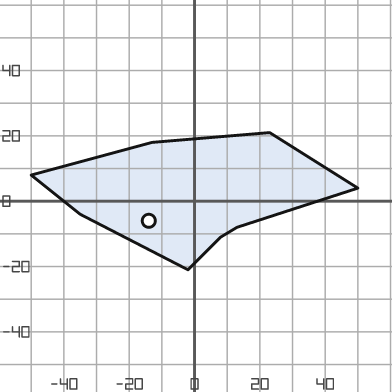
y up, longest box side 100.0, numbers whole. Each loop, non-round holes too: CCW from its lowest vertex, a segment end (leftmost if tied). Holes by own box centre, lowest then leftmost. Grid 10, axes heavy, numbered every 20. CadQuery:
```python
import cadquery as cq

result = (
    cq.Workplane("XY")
    .moveTo(-2.0, -21.0)
    .lineTo(8.0, -11.0)
    .lineTo(13.0, -8.0)
    .lineTo(50.0, 4.0)
    .lineTo(23.0, 21.0)
    .lineTo(-13.0, 18.0)
    .lineTo(-50.0, 8.0)
    .lineTo(-35.0, -4.0)
    .close()
    .moveTo(-14.0, -6.0)
    .circle(2.0)
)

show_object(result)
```